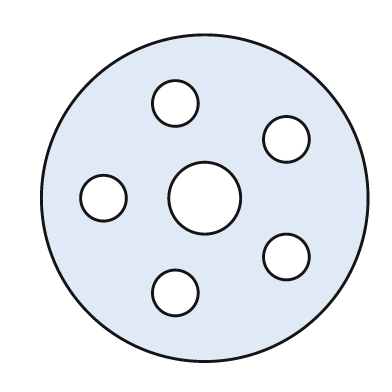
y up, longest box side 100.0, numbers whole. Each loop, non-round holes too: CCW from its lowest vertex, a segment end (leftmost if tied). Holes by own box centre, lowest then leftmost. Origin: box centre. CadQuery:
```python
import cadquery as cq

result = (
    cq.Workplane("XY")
    .moveTo(0.0, 0.0)
    .circle(50.0)
    .moveTo(-9.0, -29.0)
    .circle(7.0)
    .moveTo(25.0, -18.0)
    .circle(7.0)
    .moveTo(-31.0, 0.0)
    .circle(7.0)
    .moveTo(0.0, 0.0)
    .circle(11.0)
    .moveTo(25.0, 18.0)
    .circle(7.0)
    .moveTo(-9.0, 29.0)
    .circle(7.0)
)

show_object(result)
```